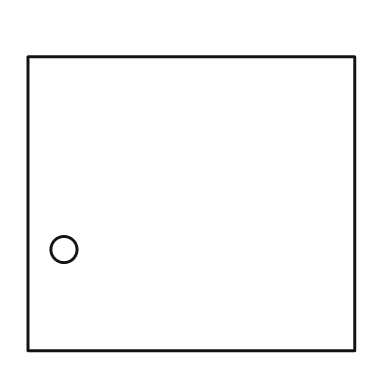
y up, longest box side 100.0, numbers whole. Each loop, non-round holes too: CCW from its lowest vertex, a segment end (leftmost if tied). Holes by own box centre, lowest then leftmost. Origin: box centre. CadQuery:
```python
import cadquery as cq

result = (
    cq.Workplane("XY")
    .moveTo(-50.0, -45.0)
    .lineTo(50.0, -45.0)
    .lineTo(50.0, 45.0)
    .lineTo(-50.0, 45.0)
    .close()
    .moveTo(-39.0, -14.0)
    .circle(4.0)
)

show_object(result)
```